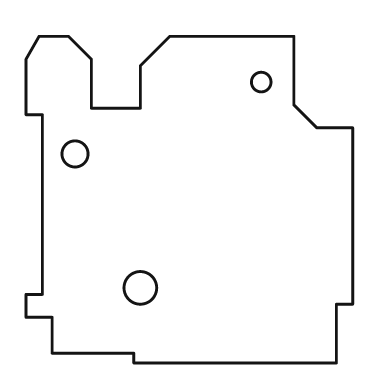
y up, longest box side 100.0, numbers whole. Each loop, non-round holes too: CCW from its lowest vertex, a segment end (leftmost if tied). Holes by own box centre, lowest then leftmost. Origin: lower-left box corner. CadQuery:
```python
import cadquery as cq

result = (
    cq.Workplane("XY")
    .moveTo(33.0, 0.0)
    .lineTo(95.0, 0.0)
    .lineTo(95.0, 18.0)
    .lineTo(100.0, 18.0)
    .lineTo(100.0, 72.0)
    .lineTo(89.0, 72.0)
    .lineTo(82.0, 79.0)
    .lineTo(82.0, 100.0)
    .lineTo(44.0, 100.0)
    .lineTo(35.0, 91.0)
    .lineTo(35.0, 78.0)
    .lineTo(20.0, 78.0)
    .lineTo(20.0, 93.0)
    .lineTo(13.0, 100.0)
    .lineTo(4.0, 100.0)
    .lineTo(0.0, 93.0)
    .lineTo(0.0, 76.0)
    .lineTo(5.0, 76.0)
    .lineTo(5.0, 21.0)
    .lineTo(0.0, 21.0)
    .lineTo(0.0, 14.0)
    .lineTo(8.0, 14.0)
    .lineTo(8.0, 3.0)
    .lineTo(33.0, 3.0)
    .close()
    .moveTo(35.0, 23.0)
    .circle(5.0)
    .moveTo(15.0, 64.0)
    .circle(4.0)
    .moveTo(72.0, 86.0)
    .circle(3.0)
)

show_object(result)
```